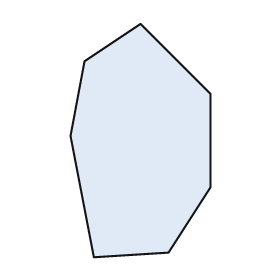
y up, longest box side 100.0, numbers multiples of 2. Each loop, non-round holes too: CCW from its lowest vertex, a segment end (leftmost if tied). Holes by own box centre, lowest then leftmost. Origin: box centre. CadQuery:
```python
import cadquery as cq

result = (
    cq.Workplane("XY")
    .moveTo(-20.0, -50.0)
    .lineTo(12.0, -48.0)
    .lineTo(30.0, -20.0)
    .lineTo(30.0, 20.0)
    .lineTo(0.0, 50.0)
    .lineTo(-24.0, 34.0)
    .lineTo(-30.0, 2.0)
    .close()
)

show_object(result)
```